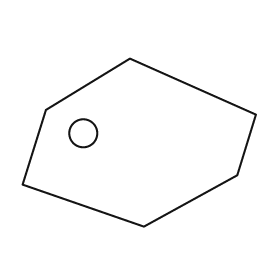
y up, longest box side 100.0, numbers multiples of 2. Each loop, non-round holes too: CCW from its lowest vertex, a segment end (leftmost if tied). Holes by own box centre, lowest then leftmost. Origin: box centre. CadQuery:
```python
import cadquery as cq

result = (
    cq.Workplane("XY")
    .moveTo(2.0, -36.0)
    .lineTo(42.0, -14.0)
    .lineTo(50.0, 12.0)
    .lineTo(-4.0, 36.0)
    .lineTo(-40.0, 14.0)
    .lineTo(-50.0, -18.0)
    .close()
    .moveTo(-24.0, 4.0)
    .circle(6.0)
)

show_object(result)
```